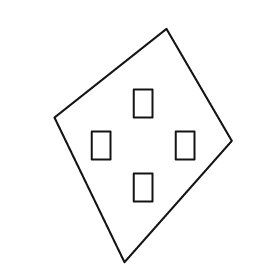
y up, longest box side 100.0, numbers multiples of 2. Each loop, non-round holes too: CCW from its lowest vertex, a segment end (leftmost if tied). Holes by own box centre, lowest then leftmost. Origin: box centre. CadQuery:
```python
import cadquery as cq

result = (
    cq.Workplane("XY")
    .moveTo(-8.0, -50.0)
    .lineTo(38.0, 2.0)
    .lineTo(10.0, 50.0)
    .lineTo(-38.0, 12.0)
    .close()
    .moveTo(-4.0, -24.0)
    .lineTo(4.0, -24.0)
    .lineTo(4.0, -12.0)
    .lineTo(-4.0, -12.0)
    .close()
    .moveTo(-22.0, -6.0)
    .lineTo(-14.0, -6.0)
    .lineTo(-14.0, 6.0)
    .lineTo(-22.0, 6.0)
    .close()
    .moveTo(14.0, -6.0)
    .lineTo(22.0, -6.0)
    .lineTo(22.0, 6.0)
    .lineTo(14.0, 6.0)
    .close()
    .moveTo(-4.0, 12.0)
    .lineTo(4.0, 12.0)
    .lineTo(4.0, 24.0)
    .lineTo(-4.0, 24.0)
    .close()
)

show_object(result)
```